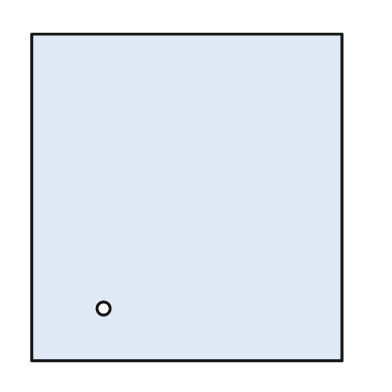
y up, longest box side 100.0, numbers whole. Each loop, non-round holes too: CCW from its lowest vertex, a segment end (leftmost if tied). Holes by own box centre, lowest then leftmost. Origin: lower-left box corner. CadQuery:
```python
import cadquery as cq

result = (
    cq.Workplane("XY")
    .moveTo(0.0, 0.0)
    .lineTo(95.0, 0.0)
    .lineTo(95.0, 100.0)
    .lineTo(0.0, 100.0)
    .close()
    .moveTo(22.0, 16.0)
    .circle(2.0)
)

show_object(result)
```